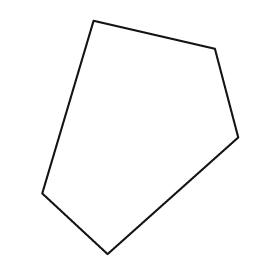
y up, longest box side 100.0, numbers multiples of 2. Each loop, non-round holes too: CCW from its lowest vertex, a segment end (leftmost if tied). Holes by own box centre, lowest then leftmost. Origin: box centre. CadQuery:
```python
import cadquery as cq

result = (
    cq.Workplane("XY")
    .moveTo(-14.0, -50.0)
    .lineTo(42.0, 0.0)
    .lineTo(32.0, 38.0)
    .lineTo(-20.0, 50.0)
    .lineTo(-42.0, -24.0)
    .close()
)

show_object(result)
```